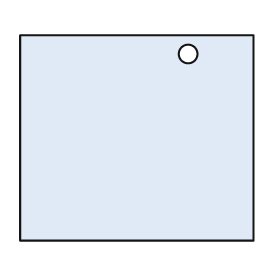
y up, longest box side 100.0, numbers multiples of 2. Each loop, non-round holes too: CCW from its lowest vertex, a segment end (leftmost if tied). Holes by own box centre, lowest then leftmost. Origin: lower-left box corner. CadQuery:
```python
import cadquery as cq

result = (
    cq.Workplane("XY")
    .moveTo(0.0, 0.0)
    .lineTo(100.0, 0.0)
    .lineTo(100.0, 88.0)
    .lineTo(0.0, 88.0)
    .close()
    .moveTo(72.0, 80.0)
    .circle(4.0)
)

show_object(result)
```